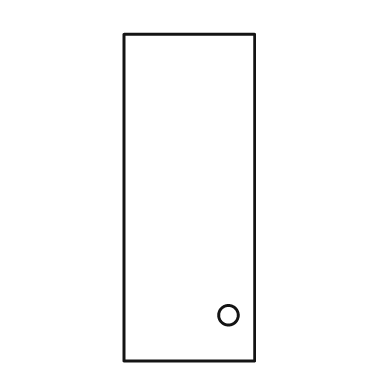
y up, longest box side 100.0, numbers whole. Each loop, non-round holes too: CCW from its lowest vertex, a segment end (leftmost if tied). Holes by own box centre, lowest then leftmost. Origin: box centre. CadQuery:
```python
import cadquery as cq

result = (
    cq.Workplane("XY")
    .moveTo(-20.0, -50.0)
    .lineTo(20.0, -50.0)
    .lineTo(20.0, 50.0)
    .lineTo(-20.0, 50.0)
    .close()
    .moveTo(12.0, -36.0)
    .circle(3.0)
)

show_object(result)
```